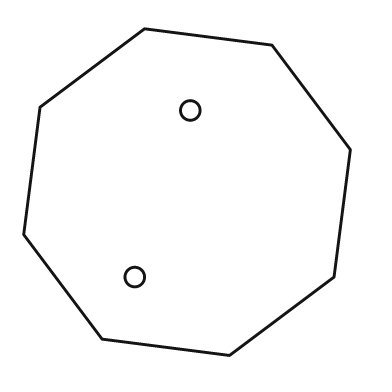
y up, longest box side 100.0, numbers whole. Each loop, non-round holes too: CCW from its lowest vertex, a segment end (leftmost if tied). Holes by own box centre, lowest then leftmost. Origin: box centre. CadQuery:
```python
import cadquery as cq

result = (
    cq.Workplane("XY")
    .moveTo(13.0, -50.0)
    .lineTo(45.0, -26.0)
    .lineTo(50.0, 13.0)
    .lineTo(26.0, 45.0)
    .lineTo(-13.0, 50.0)
    .lineTo(-45.0, 26.0)
    .lineTo(-50.0, -13.0)
    .lineTo(-26.0, -45.0)
    .close()
    .moveTo(-16.0, -26.0)
    .circle(3.0)
    .moveTo(1.0, 25.0)
    .circle(3.0)
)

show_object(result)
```